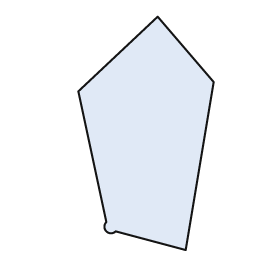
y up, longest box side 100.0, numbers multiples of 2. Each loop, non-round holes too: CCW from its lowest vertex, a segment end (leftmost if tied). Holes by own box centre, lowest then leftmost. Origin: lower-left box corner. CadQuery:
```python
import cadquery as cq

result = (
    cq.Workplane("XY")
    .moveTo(46.0, 0.0)
    .lineTo(58.0, 72.0)
    .lineTo(34.0, 100.0)
    .lineTo(0.0, 68.0)
    .lineTo(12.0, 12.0)
    .threePointArc((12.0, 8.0), (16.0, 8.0))
    .close()
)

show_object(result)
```